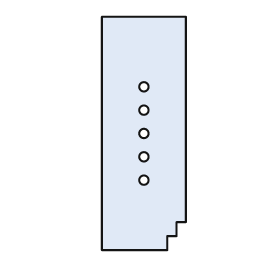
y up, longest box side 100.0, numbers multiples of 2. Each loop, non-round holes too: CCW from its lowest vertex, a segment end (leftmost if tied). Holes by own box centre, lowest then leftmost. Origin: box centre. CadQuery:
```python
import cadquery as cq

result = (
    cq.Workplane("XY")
    .moveTo(-18.0, -50.0)
    .lineTo(10.0, -50.0)
    .lineTo(10.0, -44.0)
    .lineTo(14.0, -44.0)
    .lineTo(14.0, -38.0)
    .lineTo(18.0, -38.0)
    .lineTo(18.0, 50.0)
    .lineTo(-18.0, 50.0)
    .close()
    .moveTo(0.0, -20.0)
    .circle(2.0)
    .moveTo(0.0, -10.0)
    .circle(2.0)
    .moveTo(0.0, 0.0)
    .circle(2.0)
    .moveTo(0.0, 10.0)
    .circle(2.0)
    .moveTo(0.0, 20.0)
    .circle(2.0)
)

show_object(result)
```